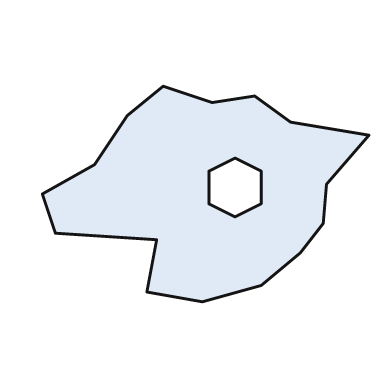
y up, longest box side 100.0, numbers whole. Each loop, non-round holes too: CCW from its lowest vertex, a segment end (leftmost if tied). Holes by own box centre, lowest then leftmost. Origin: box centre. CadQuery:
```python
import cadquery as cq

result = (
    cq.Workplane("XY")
    .moveTo(-1.0, -33.0)
    .lineTo(17.0, -28.0)
    .lineTo(29.0, -18.0)
    .lineTo(36.0, -9.0)
    .lineTo(37.0, 3.0)
    .lineTo(50.0, 18.0)
    .lineTo(26.0, 22.0)
    .lineTo(15.0, 30.0)
    .lineTo(2.0, 28.0)
    .lineTo(-13.0, 33.0)
    .lineTo(-24.0, 24.0)
    .lineTo(-34.0, 9.0)
    .lineTo(-50.0, 0.0)
    .lineTo(-46.0, -12.0)
    .lineTo(-15.0, -14.0)
    .lineTo(-18.0, -30.0)
    .close()
    .moveTo(9.0, -7.0)
    .lineTo(17.0, -3.0)
    .lineTo(17.0, 7.0)
    .lineTo(9.0, 11.0)
    .lineTo(1.0, 7.0)
    .lineTo(1.0, -3.0)
    .close()
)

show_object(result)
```